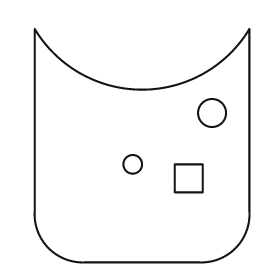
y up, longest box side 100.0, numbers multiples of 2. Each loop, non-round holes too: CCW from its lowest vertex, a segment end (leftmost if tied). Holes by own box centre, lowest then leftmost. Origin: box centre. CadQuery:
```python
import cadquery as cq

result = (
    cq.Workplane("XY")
    .moveTo(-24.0, -50.0)
    .lineTo(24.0, -50.0)
    .threePointArc((40.0, -44.0), (46.0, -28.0))
    .lineTo(46.0, 50.0)
    .threePointArc((0.0, 24.0), (-46.0, 50.0))
    .lineTo(-46.0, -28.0)
    .threePointArc((-40.0, -44.0), (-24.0, -50.0))
    .close()
    .moveTo(14.0, -20.0)
    .lineTo(26.0, -20.0)
    .lineTo(26.0, -8.0)
    .lineTo(14.0, -8.0)
    .close()
    .moveTo(-4.0, -8.0)
    .circle(4.0)
    .moveTo(30.0, 14.0)
    .circle(6.0)
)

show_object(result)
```